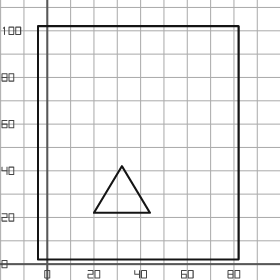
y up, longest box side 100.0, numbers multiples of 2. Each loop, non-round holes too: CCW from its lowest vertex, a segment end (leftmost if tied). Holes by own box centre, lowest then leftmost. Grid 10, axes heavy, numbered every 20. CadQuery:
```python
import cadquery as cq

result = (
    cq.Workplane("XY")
    .moveTo(-4.0, 2.0)
    .lineTo(82.0, 2.0)
    .lineTo(82.0, 102.0)
    .lineTo(-4.0, 102.0)
    .close()
    .moveTo(20.0, 22.0)
    .lineTo(44.0, 22.0)
    .lineTo(32.0, 42.0)
    .close()
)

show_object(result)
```